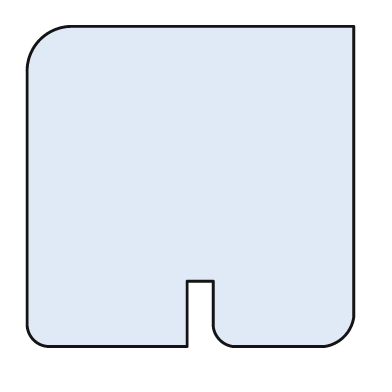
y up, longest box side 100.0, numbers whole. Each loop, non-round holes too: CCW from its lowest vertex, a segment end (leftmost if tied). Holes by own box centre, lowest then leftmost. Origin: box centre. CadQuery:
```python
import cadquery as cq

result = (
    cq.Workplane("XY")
    .moveTo(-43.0, -49.0)
    .lineTo(-1.0, -49.0)
    .lineTo(-1.0, -29.0)
    .lineTo(7.0, -29.0)
    .lineTo(7.0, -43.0)
    .threePointArc((9.0, -47.0), (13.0, -49.0))
    .lineTo(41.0, -49.0)
    .threePointArc((47.0, -46.0), (50.0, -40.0))
    .lineTo(50.0, 49.0)
    .lineTo(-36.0, 49.0)
    .threePointArc((-46.0, 45.0), (-50.0, 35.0))
    .lineTo(-50.0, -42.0)
    .threePointArc((-48.0, -47.0), (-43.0, -49.0))
    .close()
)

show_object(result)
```